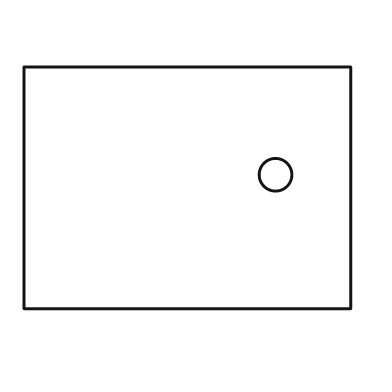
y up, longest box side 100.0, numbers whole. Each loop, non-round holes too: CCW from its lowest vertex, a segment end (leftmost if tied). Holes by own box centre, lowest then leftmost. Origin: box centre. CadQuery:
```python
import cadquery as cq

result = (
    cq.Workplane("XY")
    .moveTo(-50.0, -37.0)
    .lineTo(50.0, -37.0)
    .lineTo(50.0, 37.0)
    .lineTo(-50.0, 37.0)
    .close()
    .moveTo(27.0, 4.0)
    .circle(5.0)
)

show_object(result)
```